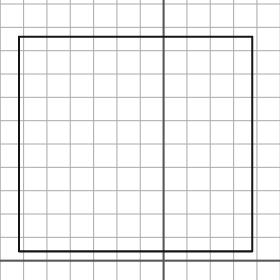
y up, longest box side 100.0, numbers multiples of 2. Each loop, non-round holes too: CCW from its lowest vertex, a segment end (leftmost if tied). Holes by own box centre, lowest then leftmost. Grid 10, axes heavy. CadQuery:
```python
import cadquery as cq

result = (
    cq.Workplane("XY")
    .moveTo(-62.0, 4.0)
    .lineTo(38.0, 4.0)
    .lineTo(38.0, 96.0)
    .lineTo(-62.0, 96.0)
    .close()
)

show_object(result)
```